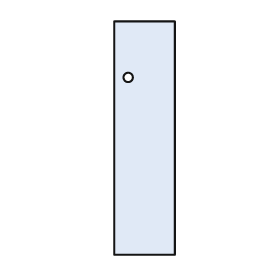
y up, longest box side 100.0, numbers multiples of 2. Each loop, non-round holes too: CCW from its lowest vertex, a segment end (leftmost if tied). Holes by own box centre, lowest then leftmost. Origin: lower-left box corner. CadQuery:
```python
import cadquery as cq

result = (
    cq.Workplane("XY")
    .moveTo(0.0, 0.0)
    .lineTo(26.0, 0.0)
    .lineTo(26.0, 100.0)
    .lineTo(0.0, 100.0)
    .close()
    .moveTo(6.0, 76.0)
    .circle(2.0)
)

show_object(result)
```